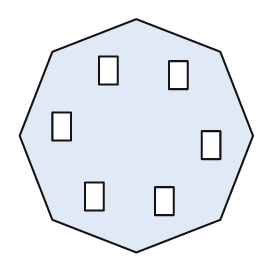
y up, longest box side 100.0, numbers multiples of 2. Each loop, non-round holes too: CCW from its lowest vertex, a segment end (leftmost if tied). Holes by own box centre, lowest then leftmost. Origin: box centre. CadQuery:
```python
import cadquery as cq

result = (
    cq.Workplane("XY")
    .moveTo(0.0, -50.0)
    .lineTo(36.0, -36.0)
    .lineTo(50.0, 0.0)
    .lineTo(36.0, 36.0)
    .lineTo(0.0, 50.0)
    .lineTo(-36.0, 36.0)
    .lineTo(-50.0, 0.0)
    .lineTo(-36.0, -36.0)
    .close()
    .moveTo(8.0, -34.0)
    .lineTo(16.0, -34.0)
    .lineTo(16.0, -22.0)
    .lineTo(8.0, -22.0)
    .close()
    .moveTo(-22.0, -32.0)
    .lineTo(-14.0, -32.0)
    .lineTo(-14.0, -20.0)
    .lineTo(-22.0, -20.0)
    .close()
    .moveTo(28.0, -10.0)
    .lineTo(36.0, -10.0)
    .lineTo(36.0, 2.0)
    .lineTo(28.0, 2.0)
    .close()
    .moveTo(-36.0, -2.0)
    .lineTo(-28.0, -2.0)
    .lineTo(-28.0, 10.0)
    .lineTo(-36.0, 10.0)
    .close()
    .moveTo(14.0, 20.0)
    .lineTo(22.0, 20.0)
    .lineTo(22.0, 32.0)
    .lineTo(14.0, 32.0)
    .close()
    .moveTo(-16.0, 22.0)
    .lineTo(-8.0, 22.0)
    .lineTo(-8.0, 34.0)
    .lineTo(-16.0, 34.0)
    .close()
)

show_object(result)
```